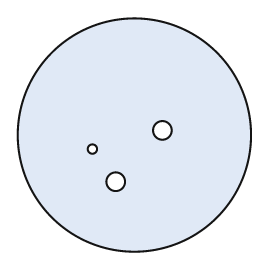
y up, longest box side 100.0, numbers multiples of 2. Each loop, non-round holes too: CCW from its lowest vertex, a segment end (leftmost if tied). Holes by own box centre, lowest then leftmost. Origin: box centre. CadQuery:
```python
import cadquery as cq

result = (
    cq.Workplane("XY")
    .moveTo(0.0, 0.0)
    .circle(50.0)
    .moveTo(-8.0, -20.0)
    .circle(4.0)
    .moveTo(-18.0, -6.0)
    .circle(2.0)
    .moveTo(12.0, 2.0)
    .circle(4.0)
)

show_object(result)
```